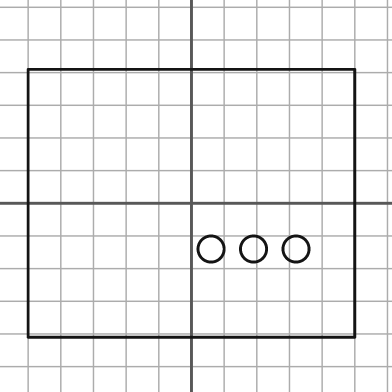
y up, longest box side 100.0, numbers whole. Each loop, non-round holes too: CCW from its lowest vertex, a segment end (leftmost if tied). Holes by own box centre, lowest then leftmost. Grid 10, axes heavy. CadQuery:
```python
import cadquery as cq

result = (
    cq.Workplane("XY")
    .moveTo(-50.0, -41.0)
    .lineTo(50.0, -41.0)
    .lineTo(50.0, 41.0)
    .lineTo(-50.0, 41.0)
    .close()
    .moveTo(6.0, -14.0)
    .circle(4.0)
    .moveTo(19.0, -14.0)
    .circle(4.0)
    .moveTo(32.0, -14.0)
    .circle(4.0)
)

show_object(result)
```